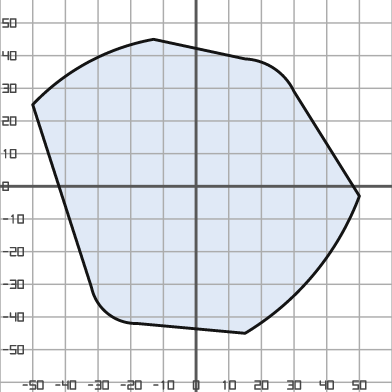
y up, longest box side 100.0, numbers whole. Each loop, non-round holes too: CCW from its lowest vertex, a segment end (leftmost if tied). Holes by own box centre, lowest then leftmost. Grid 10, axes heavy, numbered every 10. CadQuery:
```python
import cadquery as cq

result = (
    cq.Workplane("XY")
    .moveTo(15.0, -45.0)
    .threePointArc((36.0, -27.0), (50.0, -3.0))
    .lineTo(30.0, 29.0)
    .threePointArc((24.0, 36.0), (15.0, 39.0))
    .lineTo(-13.0, 45.0)
    .threePointArc((-33.0, 38.0), (-50.0, 25.0))
    .lineTo(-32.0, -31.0)
    .threePointArc((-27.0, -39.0), (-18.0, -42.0))
    .close()
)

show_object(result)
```